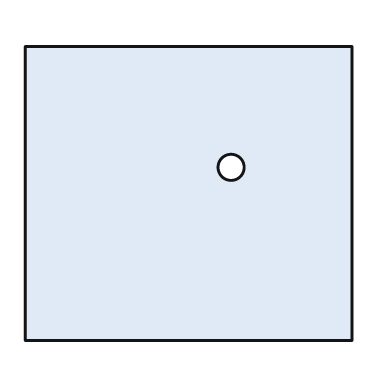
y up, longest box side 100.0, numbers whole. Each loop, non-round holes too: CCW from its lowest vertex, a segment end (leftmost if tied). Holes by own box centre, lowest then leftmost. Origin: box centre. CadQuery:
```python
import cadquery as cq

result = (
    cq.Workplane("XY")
    .moveTo(-50.0, -45.0)
    .lineTo(50.0, -45.0)
    .lineTo(50.0, 45.0)
    .lineTo(-50.0, 45.0)
    .close()
    .moveTo(13.0, 8.0)
    .circle(4.0)
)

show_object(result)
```